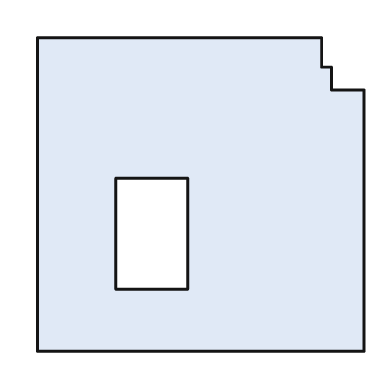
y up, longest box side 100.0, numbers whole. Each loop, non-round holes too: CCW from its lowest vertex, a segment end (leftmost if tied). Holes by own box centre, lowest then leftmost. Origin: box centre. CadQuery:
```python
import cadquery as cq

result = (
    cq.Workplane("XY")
    .moveTo(-50.0, -48.0)
    .lineTo(50.0, -48.0)
    .lineTo(50.0, 32.0)
    .lineTo(40.0, 32.0)
    .lineTo(40.0, 39.0)
    .lineTo(37.0, 39.0)
    .lineTo(37.0, 48.0)
    .lineTo(-50.0, 48.0)
    .close()
    .moveTo(-26.0, -29.0)
    .lineTo(-4.0, -29.0)
    .lineTo(-4.0, 5.0)
    .lineTo(-26.0, 5.0)
    .close()
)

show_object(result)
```